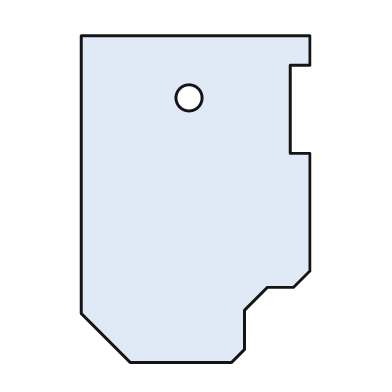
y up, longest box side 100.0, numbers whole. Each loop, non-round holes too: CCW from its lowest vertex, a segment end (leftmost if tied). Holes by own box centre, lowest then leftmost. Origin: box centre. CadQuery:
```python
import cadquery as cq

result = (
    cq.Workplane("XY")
    .moveTo(-20.0, -50.0)
    .lineTo(11.0, -50.0)
    .lineTo(15.0, -46.0)
    .lineTo(15.0, -34.0)
    .lineTo(22.0, -27.0)
    .lineTo(30.0, -27.0)
    .lineTo(35.0, -22.0)
    .lineTo(35.0, 14.0)
    .lineTo(29.0, 14.0)
    .lineTo(29.0, 41.0)
    .lineTo(35.0, 41.0)
    .lineTo(35.0, 50.0)
    .lineTo(-35.0, 50.0)
    .lineTo(-35.0, -35.0)
    .close()
    .moveTo(-2.0, 31.0)
    .circle(4.0)
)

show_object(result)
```